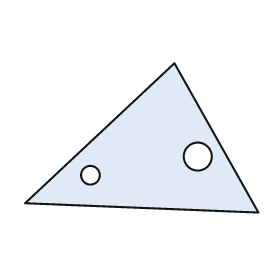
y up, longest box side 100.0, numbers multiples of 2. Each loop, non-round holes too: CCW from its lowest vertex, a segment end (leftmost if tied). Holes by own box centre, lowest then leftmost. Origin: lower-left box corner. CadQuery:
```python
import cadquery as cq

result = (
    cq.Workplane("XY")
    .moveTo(100.0, 0.0)
    .lineTo(64.0, 64.0)
    .lineTo(0.0, 4.0)
    .close()
    .moveTo(28.0, 16.0)
    .circle(4.0)
    .moveTo(74.0, 24.0)
    .circle(6.0)
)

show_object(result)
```